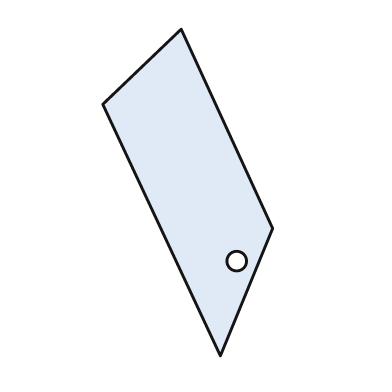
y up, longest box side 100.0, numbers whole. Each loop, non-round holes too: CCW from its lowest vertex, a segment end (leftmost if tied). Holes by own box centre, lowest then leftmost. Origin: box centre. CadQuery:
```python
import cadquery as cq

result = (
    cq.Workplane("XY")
    .moveTo(10.0, -50.0)
    .lineTo(26.0, -11.0)
    .lineTo(-2.0, 50.0)
    .lineTo(-26.0, 27.0)
    .close()
    .moveTo(15.0, -21.0)
    .circle(3.0)
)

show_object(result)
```